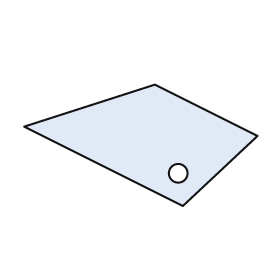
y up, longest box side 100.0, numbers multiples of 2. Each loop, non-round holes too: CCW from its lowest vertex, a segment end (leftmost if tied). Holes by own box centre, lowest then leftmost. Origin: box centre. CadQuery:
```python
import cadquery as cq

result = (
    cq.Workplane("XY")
    .moveTo(18.0, -26.0)
    .lineTo(50.0, 4.0)
    .lineTo(6.0, 26.0)
    .lineTo(-50.0, 8.0)
    .close()
    .moveTo(16.0, -12.0)
    .circle(4.0)
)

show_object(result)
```